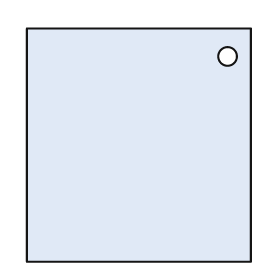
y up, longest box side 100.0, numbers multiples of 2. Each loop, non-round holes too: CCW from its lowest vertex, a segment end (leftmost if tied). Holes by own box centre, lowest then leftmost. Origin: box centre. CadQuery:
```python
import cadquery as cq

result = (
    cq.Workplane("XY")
    .moveTo(-48.0, -50.0)
    .lineTo(48.0, -50.0)
    .lineTo(48.0, 50.0)
    .lineTo(-48.0, 50.0)
    .close()
    .moveTo(38.0, 38.0)
    .circle(4.0)
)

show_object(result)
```